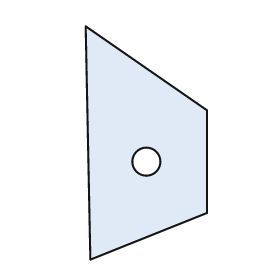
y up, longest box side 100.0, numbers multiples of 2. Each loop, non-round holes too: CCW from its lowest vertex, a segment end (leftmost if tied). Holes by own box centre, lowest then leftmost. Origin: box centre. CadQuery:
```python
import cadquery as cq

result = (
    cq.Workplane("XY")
    .moveTo(-24.0, -50.0)
    .lineTo(26.0, -30.0)
    .lineTo(26.0, 14.0)
    .lineTo(-26.0, 50.0)
    .close()
    .moveTo(0.0, -8.0)
    .circle(6.0)
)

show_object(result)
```